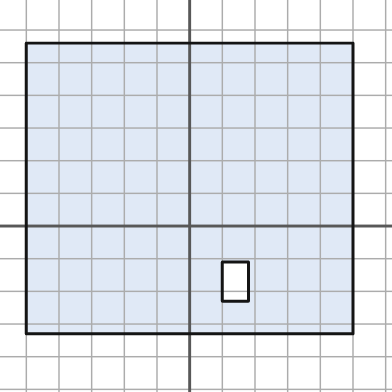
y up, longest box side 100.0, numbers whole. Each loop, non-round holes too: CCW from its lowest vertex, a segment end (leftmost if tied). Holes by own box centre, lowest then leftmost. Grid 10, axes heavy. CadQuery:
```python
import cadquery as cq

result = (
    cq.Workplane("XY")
    .moveTo(-50.0, -33.0)
    .lineTo(50.0, -33.0)
    .lineTo(50.0, 56.0)
    .lineTo(-50.0, 56.0)
    .close()
    .moveTo(10.0, -23.0)
    .lineTo(18.0, -23.0)
    .lineTo(18.0, -11.0)
    .lineTo(10.0, -11.0)
    .close()
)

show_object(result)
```